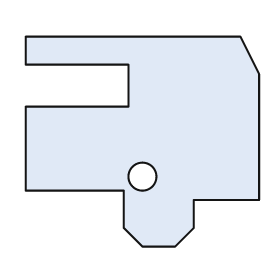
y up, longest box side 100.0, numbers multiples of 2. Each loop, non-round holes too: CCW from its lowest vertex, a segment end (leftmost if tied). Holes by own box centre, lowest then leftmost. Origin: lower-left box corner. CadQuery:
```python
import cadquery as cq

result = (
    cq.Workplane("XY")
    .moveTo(50.0, 0.0)
    .lineTo(64.0, 0.0)
    .lineTo(72.0, 8.0)
    .lineTo(72.0, 20.0)
    .lineTo(100.0, 20.0)
    .lineTo(100.0, 74.0)
    .lineTo(92.0, 90.0)
    .lineTo(0.0, 90.0)
    .lineTo(0.0, 78.0)
    .lineTo(44.0, 78.0)
    .lineTo(44.0, 60.0)
    .lineTo(0.0, 60.0)
    .lineTo(0.0, 24.0)
    .lineTo(42.0, 24.0)
    .lineTo(42.0, 8.0)
    .close()
    .moveTo(50.0, 30.0)
    .circle(6.0)
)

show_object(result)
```